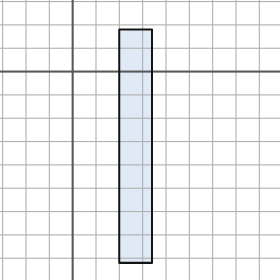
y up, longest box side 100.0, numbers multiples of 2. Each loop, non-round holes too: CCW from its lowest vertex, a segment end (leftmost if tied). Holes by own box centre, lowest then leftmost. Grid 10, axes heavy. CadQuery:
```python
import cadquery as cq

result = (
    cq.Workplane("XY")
    .moveTo(20.0, -82.0)
    .lineTo(34.0, -82.0)
    .lineTo(34.0, 18.0)
    .lineTo(20.0, 18.0)
    .close()
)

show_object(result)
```